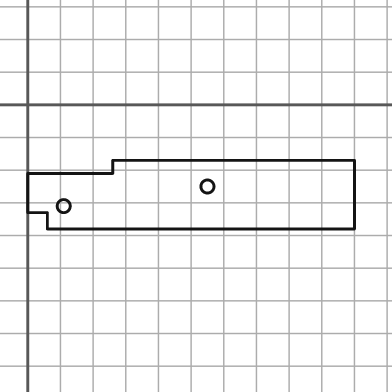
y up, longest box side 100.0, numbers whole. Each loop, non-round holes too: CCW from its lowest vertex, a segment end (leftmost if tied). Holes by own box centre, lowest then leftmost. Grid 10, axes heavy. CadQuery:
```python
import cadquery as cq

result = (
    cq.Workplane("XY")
    .moveTo(6.0, -38.0)
    .lineTo(100.0, -38.0)
    .lineTo(100.0, -17.0)
    .lineTo(26.0, -17.0)
    .lineTo(26.0, -21.0)
    .lineTo(0.0, -21.0)
    .lineTo(0.0, -33.0)
    .lineTo(6.0, -33.0)
    .close()
    .moveTo(11.0, -31.0)
    .circle(2.0)
    .moveTo(55.0, -25.0)
    .circle(2.0)
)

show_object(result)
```